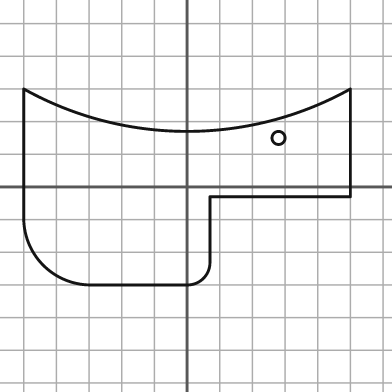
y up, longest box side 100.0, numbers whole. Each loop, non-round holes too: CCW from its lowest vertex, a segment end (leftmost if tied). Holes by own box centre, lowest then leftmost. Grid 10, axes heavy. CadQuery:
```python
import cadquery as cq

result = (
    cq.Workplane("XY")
    .moveTo(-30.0, -30.0)
    .lineTo(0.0, -30.0)
    .threePointArc((5.0, -28.0), (7.0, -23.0))
    .lineTo(7.0, -3.0)
    .lineTo(50.0, -3.0)
    .lineTo(50.0, 30.0)
    .threePointArc((0.0, 17.0), (-50.0, 30.0))
    .lineTo(-50.0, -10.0)
    .threePointArc((-44.0, -24.0), (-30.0, -30.0))
    .close()
    .moveTo(28.0, 15.0)
    .circle(2.0)
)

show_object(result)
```